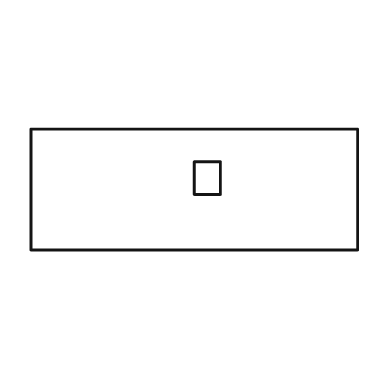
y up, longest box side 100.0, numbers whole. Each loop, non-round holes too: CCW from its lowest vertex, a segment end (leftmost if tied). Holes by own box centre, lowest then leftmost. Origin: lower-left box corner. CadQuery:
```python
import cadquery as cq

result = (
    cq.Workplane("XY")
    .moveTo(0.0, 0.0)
    .lineTo(100.0, 0.0)
    .lineTo(100.0, 37.0)
    .lineTo(0.0, 37.0)
    .close()
    .moveTo(50.0, 17.0)
    .lineTo(58.0, 17.0)
    .lineTo(58.0, 27.0)
    .lineTo(50.0, 27.0)
    .close()
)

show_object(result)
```